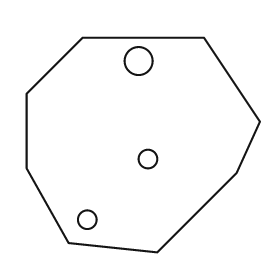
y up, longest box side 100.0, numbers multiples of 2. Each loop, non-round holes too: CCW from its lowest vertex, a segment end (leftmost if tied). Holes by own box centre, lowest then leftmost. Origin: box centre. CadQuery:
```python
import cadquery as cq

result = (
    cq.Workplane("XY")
    .moveTo(6.0, -46.0)
    .lineTo(40.0, -12.0)
    .lineTo(50.0, 10.0)
    .lineTo(26.0, 46.0)
    .lineTo(-26.0, 46.0)
    .lineTo(-50.0, 22.0)
    .lineTo(-50.0, -10.0)
    .lineTo(-32.0, -42.0)
    .close()
    .moveTo(-24.0, -32.0)
    .circle(4.0)
    .moveTo(2.0, -6.0)
    .circle(4.0)
    .moveTo(-2.0, 36.0)
    .circle(6.0)
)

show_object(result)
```